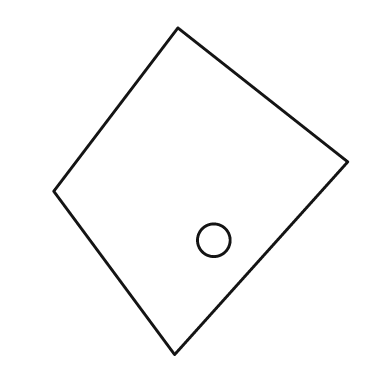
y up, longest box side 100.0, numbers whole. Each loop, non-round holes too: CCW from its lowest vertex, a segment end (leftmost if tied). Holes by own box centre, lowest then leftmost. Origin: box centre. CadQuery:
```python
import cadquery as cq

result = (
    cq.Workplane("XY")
    .moveTo(-8.0, -50.0)
    .lineTo(45.0, 9.0)
    .lineTo(-7.0, 50.0)
    .lineTo(-45.0, 0.0)
    .close()
    .moveTo(4.0, -15.0)
    .circle(5.0)
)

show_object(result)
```